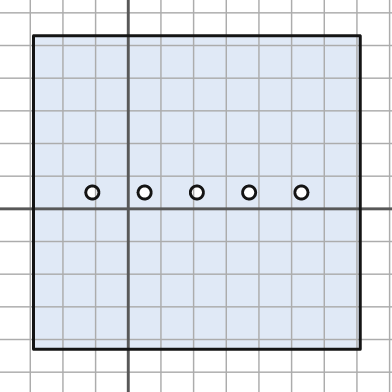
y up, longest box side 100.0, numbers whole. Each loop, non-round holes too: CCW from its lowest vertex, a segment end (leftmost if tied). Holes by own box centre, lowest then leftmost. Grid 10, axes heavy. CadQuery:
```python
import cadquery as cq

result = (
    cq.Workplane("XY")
    .moveTo(-29.0, -43.0)
    .lineTo(71.0, -43.0)
    .lineTo(71.0, 53.0)
    .lineTo(-29.0, 53.0)
    .close()
    .moveTo(-11.0, 5.0)
    .circle(2.0)
    .moveTo(5.0, 5.0)
    .circle(2.0)
    .moveTo(21.0, 5.0)
    .circle(2.0)
    .moveTo(37.0, 5.0)
    .circle(2.0)
    .moveTo(53.0, 5.0)
    .circle(2.0)
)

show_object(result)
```